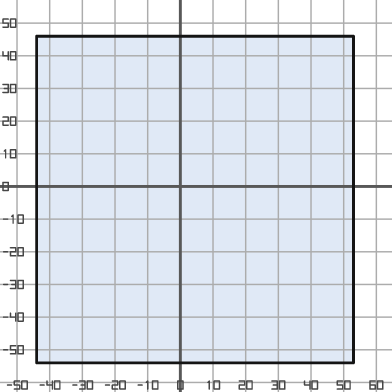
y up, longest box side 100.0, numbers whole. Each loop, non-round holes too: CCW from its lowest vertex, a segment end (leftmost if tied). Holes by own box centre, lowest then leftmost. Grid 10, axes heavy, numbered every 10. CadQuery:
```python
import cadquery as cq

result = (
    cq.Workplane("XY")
    .moveTo(-44.0, -54.0)
    .lineTo(53.0, -54.0)
    .lineTo(53.0, 46.0)
    .lineTo(-44.0, 46.0)
    .close()
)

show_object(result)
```